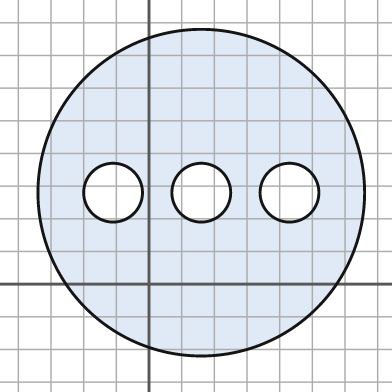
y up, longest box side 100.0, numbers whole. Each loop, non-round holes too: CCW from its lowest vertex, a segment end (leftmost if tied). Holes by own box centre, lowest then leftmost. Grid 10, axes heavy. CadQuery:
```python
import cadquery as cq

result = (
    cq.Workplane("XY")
    .moveTo(16.0, 28.0)
    .circle(50.0)
    .moveTo(-11.0, 28.0)
    .circle(9.0)
    .moveTo(16.0, 28.0)
    .circle(9.0)
    .moveTo(43.0, 28.0)
    .circle(9.0)
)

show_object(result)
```